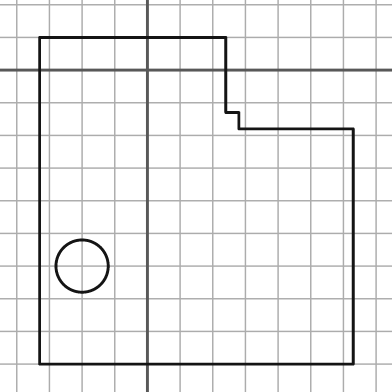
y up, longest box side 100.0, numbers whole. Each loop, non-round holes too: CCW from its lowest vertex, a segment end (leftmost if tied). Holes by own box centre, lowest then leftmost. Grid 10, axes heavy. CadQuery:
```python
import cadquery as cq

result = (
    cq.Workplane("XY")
    .moveTo(-33.0, -90.0)
    .lineTo(63.0, -90.0)
    .lineTo(63.0, -18.0)
    .lineTo(28.0, -18.0)
    .lineTo(28.0, -13.0)
    .lineTo(24.0, -13.0)
    .lineTo(24.0, 10.0)
    .lineTo(-33.0, 10.0)
    .close()
    .moveTo(-20.0, -60.0)
    .circle(8.0)
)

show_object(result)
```